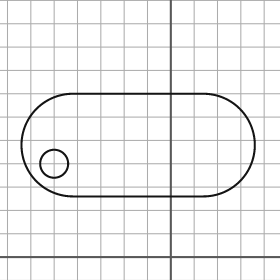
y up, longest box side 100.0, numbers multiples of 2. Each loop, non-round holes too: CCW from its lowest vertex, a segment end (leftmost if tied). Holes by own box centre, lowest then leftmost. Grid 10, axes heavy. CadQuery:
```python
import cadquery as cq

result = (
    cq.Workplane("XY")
    .moveTo(-42.0, 26.0)
    .lineTo(14.0, 26.0)
    .threePointArc((36.0, 48.0), (14.0, 70.0))
    .lineTo(-42.0, 70.0)
    .threePointArc((-64.0, 48.0), (-42.0, 26.0))
    .close()
    .moveTo(-50.0, 40.0)
    .circle(6.0)
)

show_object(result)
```